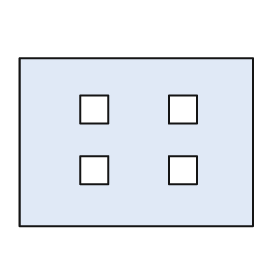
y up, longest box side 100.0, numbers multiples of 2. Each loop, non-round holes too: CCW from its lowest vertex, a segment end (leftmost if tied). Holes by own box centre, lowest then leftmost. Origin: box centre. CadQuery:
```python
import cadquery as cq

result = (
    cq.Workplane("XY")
    .moveTo(-50.0, -36.0)
    .lineTo(50.0, -36.0)
    .lineTo(50.0, 36.0)
    .lineTo(-50.0, 36.0)
    .close()
    .moveTo(-24.0, -18.0)
    .lineTo(-12.0, -18.0)
    .lineTo(-12.0, -6.0)
    .lineTo(-24.0, -6.0)
    .close()
    .moveTo(14.0, -18.0)
    .lineTo(26.0, -18.0)
    .lineTo(26.0, -6.0)
    .lineTo(14.0, -6.0)
    .close()
    .moveTo(-24.0, 8.0)
    .lineTo(-12.0, 8.0)
    .lineTo(-12.0, 20.0)
    .lineTo(-24.0, 20.0)
    .close()
    .moveTo(14.0, 8.0)
    .lineTo(26.0, 8.0)
    .lineTo(26.0, 20.0)
    .lineTo(14.0, 20.0)
    .close()
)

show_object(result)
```